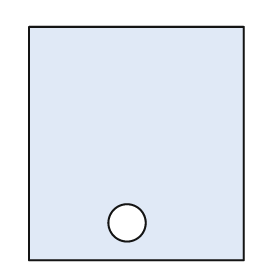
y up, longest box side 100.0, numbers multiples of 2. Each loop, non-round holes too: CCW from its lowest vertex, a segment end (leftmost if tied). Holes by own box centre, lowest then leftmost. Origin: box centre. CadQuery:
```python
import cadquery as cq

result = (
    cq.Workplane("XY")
    .moveTo(-46.0, -50.0)
    .lineTo(46.0, -50.0)
    .lineTo(46.0, 50.0)
    .lineTo(-46.0, 50.0)
    .close()
    .moveTo(-4.0, -34.0)
    .circle(8.0)
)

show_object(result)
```